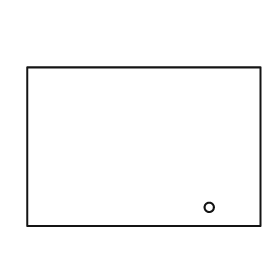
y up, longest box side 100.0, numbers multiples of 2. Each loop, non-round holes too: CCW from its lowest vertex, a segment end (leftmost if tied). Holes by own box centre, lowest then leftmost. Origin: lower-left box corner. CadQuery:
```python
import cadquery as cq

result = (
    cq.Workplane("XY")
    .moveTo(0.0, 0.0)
    .lineTo(100.0, 0.0)
    .lineTo(100.0, 68.0)
    .lineTo(0.0, 68.0)
    .close()
    .moveTo(78.0, 8.0)
    .circle(2.0)
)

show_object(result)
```